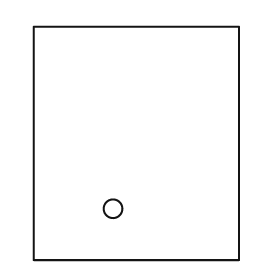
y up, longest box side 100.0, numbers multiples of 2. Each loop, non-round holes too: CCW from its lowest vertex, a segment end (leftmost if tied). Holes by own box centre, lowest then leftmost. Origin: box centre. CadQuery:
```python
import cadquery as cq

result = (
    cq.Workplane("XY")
    .moveTo(-44.0, -50.0)
    .lineTo(44.0, -50.0)
    .lineTo(44.0, 50.0)
    .lineTo(-44.0, 50.0)
    .close()
    .moveTo(-10.0, -28.0)
    .circle(4.0)
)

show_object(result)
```